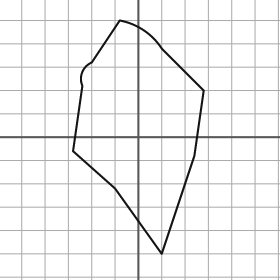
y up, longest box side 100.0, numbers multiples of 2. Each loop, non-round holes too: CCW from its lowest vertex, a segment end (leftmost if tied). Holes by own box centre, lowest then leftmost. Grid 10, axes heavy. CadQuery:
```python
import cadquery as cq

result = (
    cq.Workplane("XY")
    .moveTo(10.0, -50.0)
    .lineTo(24.0, -8.0)
    .lineTo(28.0, 20.0)
    .lineTo(10.0, 38.0)
    .threePointArc((2.0, 46.0), (-8.0, 50.0))
    .lineTo(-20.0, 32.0)
    .threePointArc((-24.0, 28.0), (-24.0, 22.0))
    .lineTo(-28.0, -6.0)
    .lineTo(-10.0, -22.0)
    .close()
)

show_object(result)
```